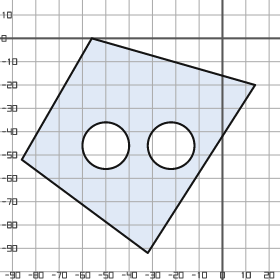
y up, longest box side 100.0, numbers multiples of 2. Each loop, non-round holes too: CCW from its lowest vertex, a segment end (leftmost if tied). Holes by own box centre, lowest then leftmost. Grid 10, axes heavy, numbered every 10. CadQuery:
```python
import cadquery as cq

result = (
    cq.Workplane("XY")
    .moveTo(-32.0, -92.0)
    .lineTo(14.0, -20.0)
    .lineTo(-56.0, 0.0)
    .lineTo(-86.0, -52.0)
    .close()
    .moveTo(-50.0, -46.0)
    .circle(10.0)
    .moveTo(-22.0, -46.0)
    .circle(10.0)
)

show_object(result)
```